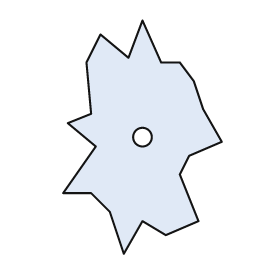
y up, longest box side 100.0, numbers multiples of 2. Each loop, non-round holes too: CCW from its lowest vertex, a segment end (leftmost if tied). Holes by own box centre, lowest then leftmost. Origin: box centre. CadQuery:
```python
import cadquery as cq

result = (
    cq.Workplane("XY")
    .moveTo(-8.0, -50.0)
    .lineTo(0.0, -36.0)
    .lineTo(10.0, -42.0)
    .lineTo(24.0, -36.0)
    .lineTo(16.0, -16.0)
    .lineTo(20.0, -8.0)
    .lineTo(34.0, -2.0)
    .lineTo(26.0, 12.0)
    .lineTo(22.0, 24.0)
    .lineTo(16.0, 32.0)
    .lineTo(8.0, 32.0)
    .lineTo(0.0, 50.0)
    .lineTo(-6.0, 34.0)
    .lineTo(-18.0, 44.0)
    .lineTo(-24.0, 32.0)
    .lineTo(-22.0, 10.0)
    .lineTo(-32.0, 6.0)
    .lineTo(-20.0, -4.0)
    .lineTo(-34.0, -24.0)
    .lineTo(-22.0, -24.0)
    .lineTo(-14.0, -32.0)
    .close()
    .moveTo(0.0, 0.0)
    .circle(4.0)
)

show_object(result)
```